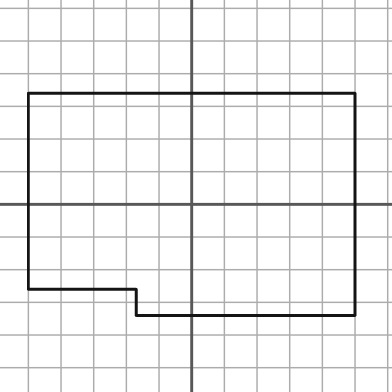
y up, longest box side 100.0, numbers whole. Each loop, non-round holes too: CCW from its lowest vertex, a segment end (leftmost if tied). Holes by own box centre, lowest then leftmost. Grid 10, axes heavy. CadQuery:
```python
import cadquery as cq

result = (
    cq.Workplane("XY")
    .moveTo(-17.0, -34.0)
    .lineTo(50.0, -34.0)
    .lineTo(50.0, 34.0)
    .lineTo(-50.0, 34.0)
    .lineTo(-50.0, -26.0)
    .lineTo(-17.0, -26.0)
    .close()
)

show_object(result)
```